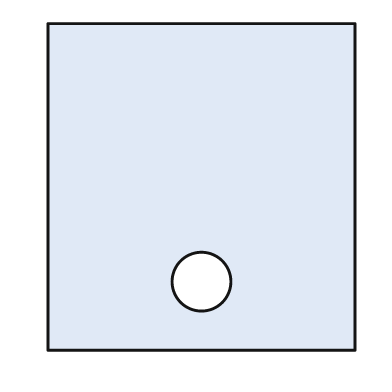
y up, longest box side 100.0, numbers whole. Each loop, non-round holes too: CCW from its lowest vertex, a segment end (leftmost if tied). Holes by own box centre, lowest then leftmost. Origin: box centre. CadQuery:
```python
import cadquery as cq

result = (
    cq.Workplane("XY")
    .moveTo(-47.0, -50.0)
    .lineTo(47.0, -50.0)
    .lineTo(47.0, 50.0)
    .lineTo(-47.0, 50.0)
    .close()
    .moveTo(0.0, -29.0)
    .circle(9.0)
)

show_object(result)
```